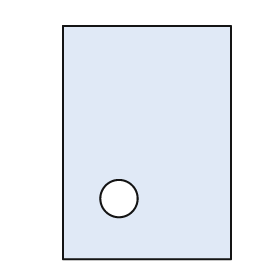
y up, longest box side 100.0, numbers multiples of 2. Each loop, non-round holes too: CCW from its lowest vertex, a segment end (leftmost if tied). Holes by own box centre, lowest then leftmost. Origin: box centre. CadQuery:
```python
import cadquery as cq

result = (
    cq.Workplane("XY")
    .moveTo(-36.0, -50.0)
    .lineTo(36.0, -50.0)
    .lineTo(36.0, 50.0)
    .lineTo(-36.0, 50.0)
    .close()
    .moveTo(-12.0, -24.0)
    .circle(8.0)
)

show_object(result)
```